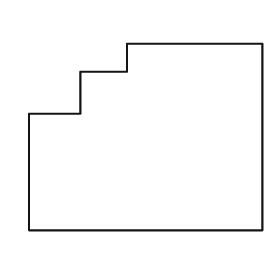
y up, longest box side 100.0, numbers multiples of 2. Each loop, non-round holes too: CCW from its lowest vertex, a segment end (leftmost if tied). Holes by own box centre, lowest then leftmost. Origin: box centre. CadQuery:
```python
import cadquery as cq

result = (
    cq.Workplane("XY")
    .moveTo(-50.0, -40.0)
    .lineTo(50.0, -40.0)
    .lineTo(50.0, 40.0)
    .lineTo(-8.0, 40.0)
    .lineTo(-8.0, 28.0)
    .lineTo(-28.0, 28.0)
    .lineTo(-28.0, 10.0)
    .lineTo(-50.0, 10.0)
    .close()
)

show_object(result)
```